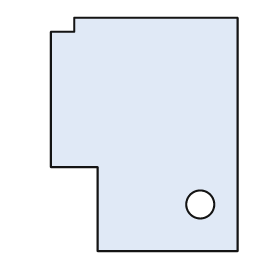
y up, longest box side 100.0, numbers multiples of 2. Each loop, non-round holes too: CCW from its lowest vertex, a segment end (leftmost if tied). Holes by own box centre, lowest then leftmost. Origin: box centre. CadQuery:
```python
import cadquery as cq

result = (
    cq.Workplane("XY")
    .moveTo(-20.0, -50.0)
    .lineTo(40.0, -50.0)
    .lineTo(40.0, 50.0)
    .lineTo(-30.0, 50.0)
    .lineTo(-30.0, 44.0)
    .lineTo(-40.0, 44.0)
    .lineTo(-40.0, -14.0)
    .lineTo(-20.0, -14.0)
    .close()
    .moveTo(24.0, -30.0)
    .circle(6.0)
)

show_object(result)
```